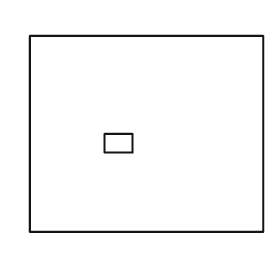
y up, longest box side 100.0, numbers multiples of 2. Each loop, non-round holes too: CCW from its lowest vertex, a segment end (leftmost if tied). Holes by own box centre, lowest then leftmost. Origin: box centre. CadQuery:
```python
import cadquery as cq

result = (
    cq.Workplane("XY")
    .moveTo(-50.0, -42.0)
    .lineTo(50.0, -42.0)
    .lineTo(50.0, 42.0)
    .lineTo(-50.0, 42.0)
    .close()
    .moveTo(-18.0, -8.0)
    .lineTo(-6.0, -8.0)
    .lineTo(-6.0, 0.0)
    .lineTo(-18.0, 0.0)
    .close()
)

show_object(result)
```